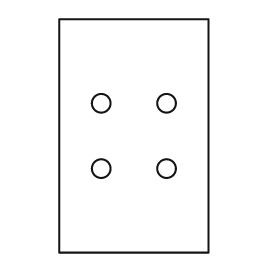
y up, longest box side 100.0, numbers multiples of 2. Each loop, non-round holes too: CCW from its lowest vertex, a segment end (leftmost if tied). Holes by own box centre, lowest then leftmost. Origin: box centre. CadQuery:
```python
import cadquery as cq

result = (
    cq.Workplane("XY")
    .moveTo(-32.0, -50.0)
    .lineTo(32.0, -50.0)
    .lineTo(32.0, 50.0)
    .lineTo(-32.0, 50.0)
    .close()
    .moveTo(-14.0, -14.0)
    .circle(4.0)
    .moveTo(14.0, -14.0)
    .circle(4.0)
    .moveTo(-14.0, 14.0)
    .circle(4.0)
    .moveTo(14.0, 14.0)
    .circle(4.0)
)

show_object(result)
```